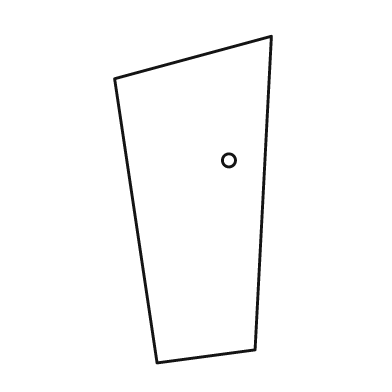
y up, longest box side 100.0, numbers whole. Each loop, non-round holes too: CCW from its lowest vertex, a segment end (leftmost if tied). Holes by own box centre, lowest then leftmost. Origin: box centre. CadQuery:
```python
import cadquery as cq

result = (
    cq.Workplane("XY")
    .moveTo(-11.0, -50.0)
    .lineTo(19.0, -46.0)
    .lineTo(24.0, 50.0)
    .lineTo(-24.0, 37.0)
    .close()
    .moveTo(11.0, 12.0)
    .circle(2.0)
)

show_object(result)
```